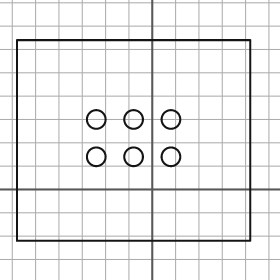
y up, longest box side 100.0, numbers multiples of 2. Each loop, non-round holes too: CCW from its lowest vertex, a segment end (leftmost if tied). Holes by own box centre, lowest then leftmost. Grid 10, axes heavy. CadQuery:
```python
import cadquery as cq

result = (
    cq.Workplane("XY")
    .moveTo(-58.0, -22.0)
    .lineTo(42.0, -22.0)
    .lineTo(42.0, 64.0)
    .lineTo(-58.0, 64.0)
    .close()
    .moveTo(-24.0, 14.0)
    .circle(4.0)
    .moveTo(-8.0, 14.0)
    .circle(4.0)
    .moveTo(8.0, 14.0)
    .circle(4.0)
    .moveTo(-24.0, 30.0)
    .circle(4.0)
    .moveTo(-8.0, 30.0)
    .circle(4.0)
    .moveTo(8.0, 30.0)
    .circle(4.0)
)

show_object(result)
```